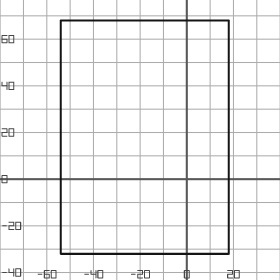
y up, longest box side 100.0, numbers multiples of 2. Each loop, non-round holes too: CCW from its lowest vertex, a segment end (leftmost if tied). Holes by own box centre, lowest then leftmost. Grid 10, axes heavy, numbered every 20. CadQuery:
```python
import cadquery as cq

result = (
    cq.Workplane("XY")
    .moveTo(-54.0, -32.0)
    .lineTo(18.0, -32.0)
    .lineTo(18.0, 68.0)
    .lineTo(-54.0, 68.0)
    .close()
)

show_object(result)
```